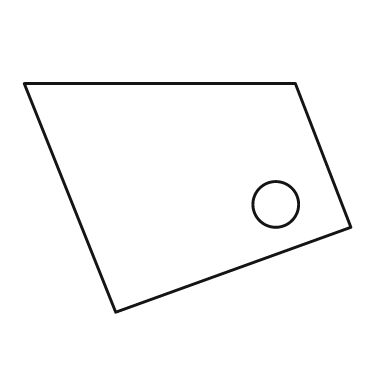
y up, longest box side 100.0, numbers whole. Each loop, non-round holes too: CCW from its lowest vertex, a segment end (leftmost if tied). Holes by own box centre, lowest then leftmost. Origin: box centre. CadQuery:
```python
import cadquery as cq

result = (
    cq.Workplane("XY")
    .moveTo(-22.0, -35.0)
    .lineTo(50.0, -9.0)
    .lineTo(33.0, 35.0)
    .lineTo(-50.0, 35.0)
    .close()
    .moveTo(27.0, -2.0)
    .circle(7.0)
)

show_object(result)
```